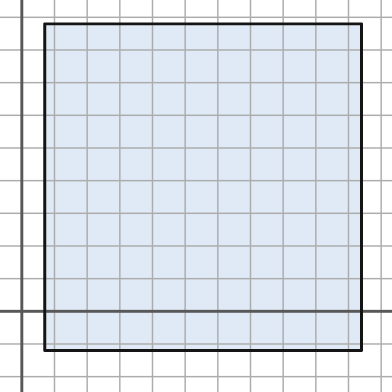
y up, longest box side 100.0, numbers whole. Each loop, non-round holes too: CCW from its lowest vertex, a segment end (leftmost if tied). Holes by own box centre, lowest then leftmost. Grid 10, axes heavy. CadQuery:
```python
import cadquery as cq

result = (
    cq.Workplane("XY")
    .moveTo(7.0, -12.0)
    .lineTo(104.0, -12.0)
    .lineTo(104.0, 88.0)
    .lineTo(7.0, 88.0)
    .close()
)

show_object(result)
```